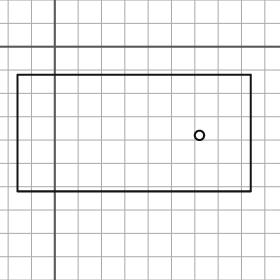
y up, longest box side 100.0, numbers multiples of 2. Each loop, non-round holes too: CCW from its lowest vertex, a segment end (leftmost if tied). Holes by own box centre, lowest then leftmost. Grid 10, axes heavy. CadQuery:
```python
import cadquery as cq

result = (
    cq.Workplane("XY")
    .moveTo(-16.0, -62.0)
    .lineTo(84.0, -62.0)
    .lineTo(84.0, -12.0)
    .lineTo(-16.0, -12.0)
    .close()
    .moveTo(62.0, -38.0)
    .circle(2.0)
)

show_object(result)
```